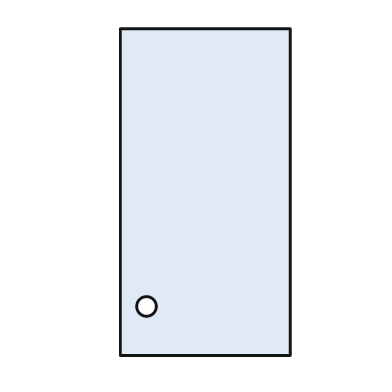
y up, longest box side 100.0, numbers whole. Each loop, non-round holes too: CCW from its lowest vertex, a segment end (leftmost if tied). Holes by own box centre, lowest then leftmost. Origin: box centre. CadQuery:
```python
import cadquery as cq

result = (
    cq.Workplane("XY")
    .moveTo(-26.0, -50.0)
    .lineTo(26.0, -50.0)
    .lineTo(26.0, 50.0)
    .lineTo(-26.0, 50.0)
    .close()
    .moveTo(-18.0, -35.0)
    .circle(3.0)
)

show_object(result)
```